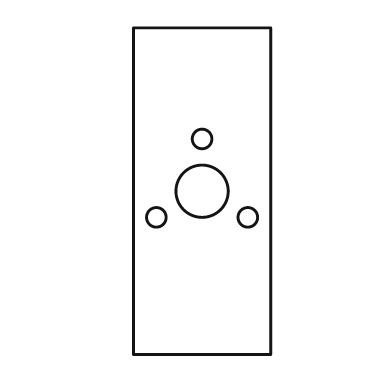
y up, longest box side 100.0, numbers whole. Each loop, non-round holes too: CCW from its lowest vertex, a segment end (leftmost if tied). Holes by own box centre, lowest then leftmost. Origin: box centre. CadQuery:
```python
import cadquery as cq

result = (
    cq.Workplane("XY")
    .moveTo(-21.0, -50.0)
    .lineTo(21.0, -50.0)
    .lineTo(21.0, 50.0)
    .lineTo(-21.0, 50.0)
    .close()
    .moveTo(-14.0, -8.0)
    .circle(3.0)
    .moveTo(14.0, -8.0)
    .circle(3.0)
    .moveTo(0.0, 0.0)
    .circle(8.0)
    .moveTo(0.0, 16.0)
    .circle(3.0)
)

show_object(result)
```